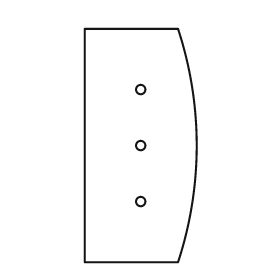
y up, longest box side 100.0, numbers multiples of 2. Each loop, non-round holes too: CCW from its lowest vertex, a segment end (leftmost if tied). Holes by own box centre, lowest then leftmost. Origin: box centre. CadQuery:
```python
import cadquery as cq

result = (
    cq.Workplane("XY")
    .moveTo(-24.0, -50.0)
    .lineTo(16.0, -50.0)
    .threePointArc((24.0, 0.0), (16.0, 50.0))
    .lineTo(-24.0, 50.0)
    .close()
    .moveTo(0.0, -24.0)
    .circle(2.0)
    .moveTo(0.0, 0.0)
    .circle(2.0)
    .moveTo(0.0, 24.0)
    .circle(2.0)
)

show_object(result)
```